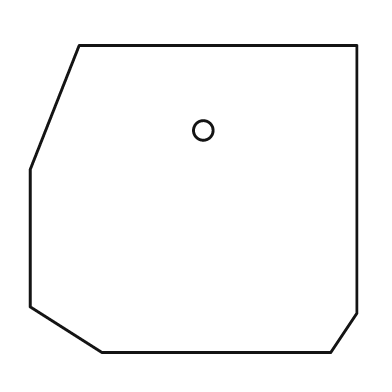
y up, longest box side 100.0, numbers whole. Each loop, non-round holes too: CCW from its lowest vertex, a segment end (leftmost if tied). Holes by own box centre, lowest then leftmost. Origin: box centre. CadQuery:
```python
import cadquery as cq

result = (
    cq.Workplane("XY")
    .moveTo(-28.0, -47.0)
    .lineTo(42.0, -47.0)
    .lineTo(50.0, -35.0)
    .lineTo(50.0, 47.0)
    .lineTo(-35.0, 47.0)
    .lineTo(-50.0, 9.0)
    .lineTo(-50.0, -33.0)
    .close()
    .moveTo(3.0, 21.0)
    .circle(3.0)
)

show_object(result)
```